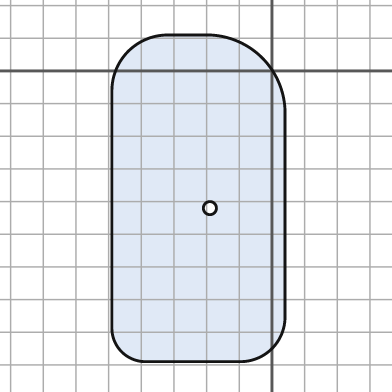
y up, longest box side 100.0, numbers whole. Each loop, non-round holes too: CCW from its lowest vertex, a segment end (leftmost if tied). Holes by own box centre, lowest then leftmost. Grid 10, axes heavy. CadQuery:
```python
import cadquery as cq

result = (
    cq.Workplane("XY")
    .moveTo(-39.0, -89.0)
    .lineTo(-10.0, -89.0)
    .threePointArc((0.0, -85.0), (4.0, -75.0))
    .lineTo(4.0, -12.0)
    .threePointArc((-3.0, 4.0), (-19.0, 11.0))
    .lineTo(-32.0, 11.0)
    .threePointArc((-44.0, 6.0), (-49.0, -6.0))
    .lineTo(-49.0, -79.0)
    .threePointArc((-46.0, -86.0), (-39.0, -89.0))
    .close()
    .moveTo(-19.0, -42.0)
    .circle(2.0)
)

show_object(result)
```